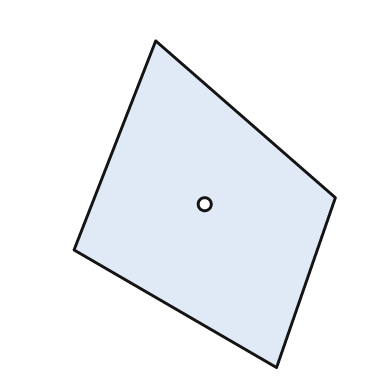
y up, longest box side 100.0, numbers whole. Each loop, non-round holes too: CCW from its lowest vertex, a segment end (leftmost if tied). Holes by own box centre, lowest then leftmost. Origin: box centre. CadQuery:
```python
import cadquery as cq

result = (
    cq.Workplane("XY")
    .moveTo(22.0, -50.0)
    .lineTo(40.0, 2.0)
    .lineTo(-15.0, 50.0)
    .lineTo(-40.0, -14.0)
    .close()
    .moveTo(0.0, 0.0)
    .circle(2.0)
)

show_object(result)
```